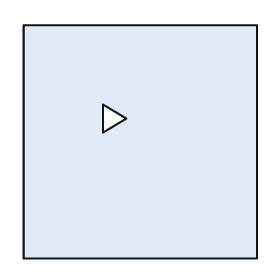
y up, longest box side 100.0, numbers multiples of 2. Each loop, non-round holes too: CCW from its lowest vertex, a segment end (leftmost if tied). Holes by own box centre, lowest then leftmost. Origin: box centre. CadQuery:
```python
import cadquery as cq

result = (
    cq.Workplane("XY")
    .moveTo(-50.0, -50.0)
    .lineTo(50.0, -50.0)
    .lineTo(50.0, 50.0)
    .lineTo(-50.0, 50.0)
    .close()
    .moveTo(-16.0, 4.0)
    .lineTo(-6.0, 10.0)
    .lineTo(-16.0, 16.0)
    .close()
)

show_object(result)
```